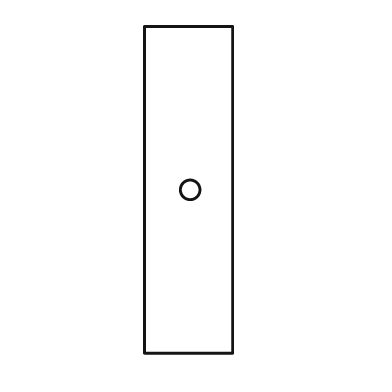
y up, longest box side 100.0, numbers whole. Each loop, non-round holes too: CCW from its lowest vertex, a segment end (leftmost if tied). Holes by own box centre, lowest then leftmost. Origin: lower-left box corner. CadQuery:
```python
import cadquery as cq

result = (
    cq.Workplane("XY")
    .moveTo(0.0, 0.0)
    .lineTo(27.0, 0.0)
    .lineTo(27.0, 100.0)
    .lineTo(0.0, 100.0)
    .close()
    .moveTo(14.0, 50.0)
    .circle(3.0)
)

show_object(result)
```